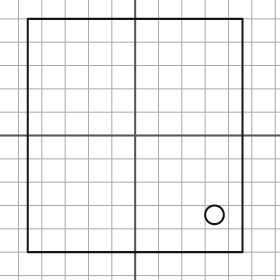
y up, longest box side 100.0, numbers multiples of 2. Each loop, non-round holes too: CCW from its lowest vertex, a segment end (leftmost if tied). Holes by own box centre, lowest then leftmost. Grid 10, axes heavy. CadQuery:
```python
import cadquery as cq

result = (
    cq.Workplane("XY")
    .moveTo(-46.0, -50.0)
    .lineTo(46.0, -50.0)
    .lineTo(46.0, 50.0)
    .lineTo(-46.0, 50.0)
    .close()
    .moveTo(34.0, -34.0)
    .circle(4.0)
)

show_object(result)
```